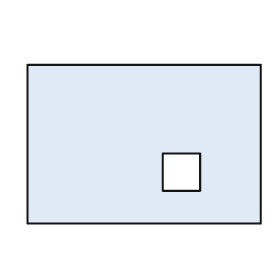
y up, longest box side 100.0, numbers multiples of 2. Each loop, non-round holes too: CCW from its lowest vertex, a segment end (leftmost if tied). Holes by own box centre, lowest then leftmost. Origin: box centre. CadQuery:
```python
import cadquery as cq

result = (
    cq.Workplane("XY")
    .moveTo(-50.0, -34.0)
    .lineTo(50.0, -34.0)
    .lineTo(50.0, 34.0)
    .lineTo(-50.0, 34.0)
    .close()
    .moveTo(8.0, -20.0)
    .lineTo(24.0, -20.0)
    .lineTo(24.0, -4.0)
    .lineTo(8.0, -4.0)
    .close()
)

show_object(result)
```